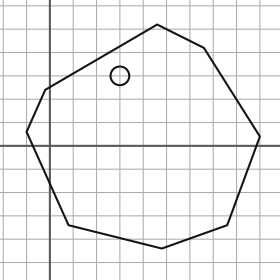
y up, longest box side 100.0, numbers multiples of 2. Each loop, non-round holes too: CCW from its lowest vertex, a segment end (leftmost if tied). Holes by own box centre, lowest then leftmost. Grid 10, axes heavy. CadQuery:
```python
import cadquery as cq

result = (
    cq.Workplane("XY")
    .moveTo(48.0, -44.0)
    .lineTo(76.0, -34.0)
    .lineTo(90.0, 4.0)
    .lineTo(66.0, 42.0)
    .lineTo(46.0, 52.0)
    .lineTo(-2.0, 24.0)
    .lineTo(-10.0, 6.0)
    .lineTo(8.0, -34.0)
    .close()
    .moveTo(30.0, 30.0)
    .circle(4.0)
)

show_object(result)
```